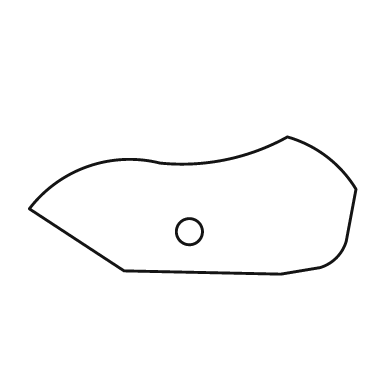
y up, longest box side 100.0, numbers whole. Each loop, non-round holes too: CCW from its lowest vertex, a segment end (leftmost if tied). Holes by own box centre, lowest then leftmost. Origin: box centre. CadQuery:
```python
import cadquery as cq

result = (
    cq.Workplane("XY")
    .moveTo(27.0, -21.0)
    .lineTo(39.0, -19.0)
    .threePointArc((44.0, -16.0), (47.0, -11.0))
    .lineTo(50.0, 5.0)
    .threePointArc((41.0, 15.0), (29.0, 21.0))
    .threePointArc((10.0, 14.0), (-10.0, 13.0))
    .threePointArc((-32.0, 12.0), (-50.0, -1.0))
    .lineTo(-21.0, -20.0)
    .close()
    .moveTo(-1.0, -8.0)
    .circle(4.0)
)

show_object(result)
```